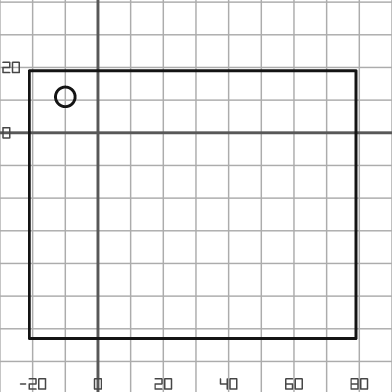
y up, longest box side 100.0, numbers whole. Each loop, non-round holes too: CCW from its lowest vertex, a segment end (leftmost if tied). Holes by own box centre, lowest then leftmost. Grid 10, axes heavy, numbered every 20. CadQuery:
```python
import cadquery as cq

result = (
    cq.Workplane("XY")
    .moveTo(-21.0, -63.0)
    .lineTo(79.0, -63.0)
    .lineTo(79.0, 19.0)
    .lineTo(-21.0, 19.0)
    .close()
    .moveTo(-10.0, 11.0)
    .circle(3.0)
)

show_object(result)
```